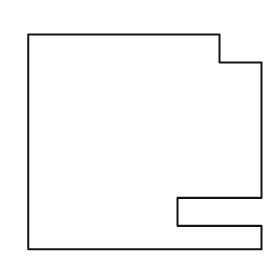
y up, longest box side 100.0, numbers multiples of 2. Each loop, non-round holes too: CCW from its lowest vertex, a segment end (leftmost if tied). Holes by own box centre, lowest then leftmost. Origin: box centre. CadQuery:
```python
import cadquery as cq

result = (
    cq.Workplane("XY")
    .moveTo(-50.0, -46.0)
    .lineTo(50.0, -46.0)
    .lineTo(50.0, -36.0)
    .lineTo(14.0, -36.0)
    .lineTo(14.0, -24.0)
    .lineTo(50.0, -24.0)
    .lineTo(50.0, 34.0)
    .lineTo(32.0, 34.0)
    .lineTo(32.0, 46.0)
    .lineTo(-50.0, 46.0)
    .close()
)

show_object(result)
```